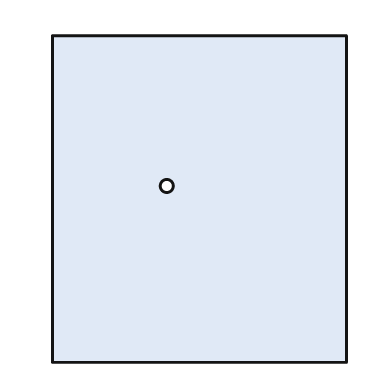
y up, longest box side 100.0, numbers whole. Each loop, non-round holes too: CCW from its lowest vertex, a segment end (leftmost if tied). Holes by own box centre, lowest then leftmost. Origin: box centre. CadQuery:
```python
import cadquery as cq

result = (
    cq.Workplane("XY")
    .moveTo(-45.0, -50.0)
    .lineTo(45.0, -50.0)
    .lineTo(45.0, 50.0)
    .lineTo(-45.0, 50.0)
    .close()
    .moveTo(-10.0, 4.0)
    .circle(2.0)
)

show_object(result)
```